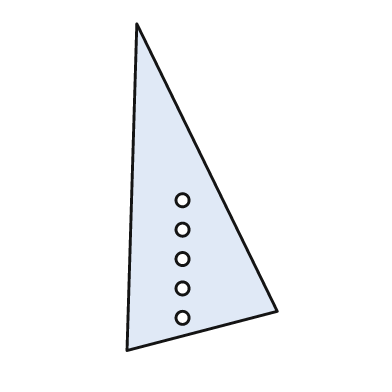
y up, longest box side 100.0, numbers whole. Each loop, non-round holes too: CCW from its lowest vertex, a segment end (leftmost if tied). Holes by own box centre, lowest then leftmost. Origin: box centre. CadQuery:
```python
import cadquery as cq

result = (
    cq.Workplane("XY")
    .moveTo(-23.0, -50.0)
    .lineTo(23.0, -38.0)
    .lineTo(-20.0, 50.0)
    .close()
    .moveTo(-6.0, -40.0)
    .circle(2.0)
    .moveTo(-6.0, -31.0)
    .circle(2.0)
    .moveTo(-6.0, -22.0)
    .circle(2.0)
    .moveTo(-6.0, -13.0)
    .circle(2.0)
    .moveTo(-6.0, -4.0)
    .circle(2.0)
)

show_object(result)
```